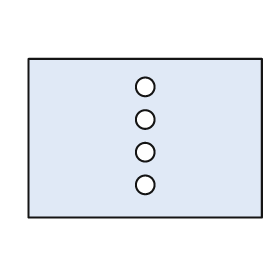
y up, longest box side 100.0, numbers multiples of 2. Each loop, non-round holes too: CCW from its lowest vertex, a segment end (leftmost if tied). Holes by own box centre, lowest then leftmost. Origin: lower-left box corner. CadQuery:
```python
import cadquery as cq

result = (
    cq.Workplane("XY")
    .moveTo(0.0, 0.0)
    .lineTo(100.0, 0.0)
    .lineTo(100.0, 68.0)
    .lineTo(0.0, 68.0)
    .close()
    .moveTo(50.0, 14.0)
    .circle(4.0)
    .moveTo(50.0, 28.0)
    .circle(4.0)
    .moveTo(50.0, 42.0)
    .circle(4.0)
    .moveTo(50.0, 56.0)
    .circle(4.0)
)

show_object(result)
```